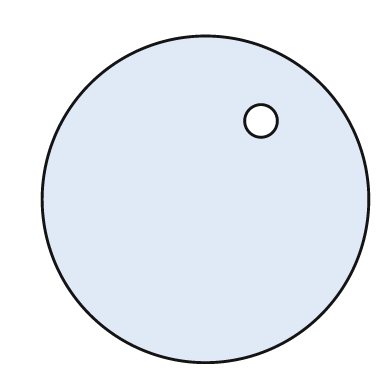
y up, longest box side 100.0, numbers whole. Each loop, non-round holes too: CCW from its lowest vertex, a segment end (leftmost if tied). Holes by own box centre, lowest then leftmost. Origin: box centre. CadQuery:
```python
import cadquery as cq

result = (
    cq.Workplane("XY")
    .moveTo(0.0, 0.0)
    .circle(50.0)
    .moveTo(17.0, 24.0)
    .circle(5.0)
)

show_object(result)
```